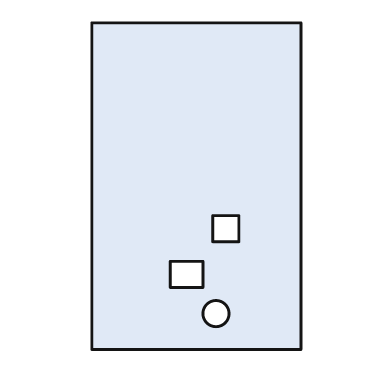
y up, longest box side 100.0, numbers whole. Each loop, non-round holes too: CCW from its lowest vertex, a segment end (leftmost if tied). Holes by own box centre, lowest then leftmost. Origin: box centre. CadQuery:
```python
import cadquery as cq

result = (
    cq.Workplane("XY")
    .moveTo(-32.0, -50.0)
    .lineTo(32.0, -50.0)
    .lineTo(32.0, 50.0)
    .lineTo(-32.0, 50.0)
    .close()
    .moveTo(6.0, -39.0)
    .circle(4.0)
    .moveTo(-8.0, -31.0)
    .lineTo(2.0, -31.0)
    .lineTo(2.0, -23.0)
    .lineTo(-8.0, -23.0)
    .close()
    .moveTo(5.0, -17.0)
    .lineTo(13.0, -17.0)
    .lineTo(13.0, -9.0)
    .lineTo(5.0, -9.0)
    .close()
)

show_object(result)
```